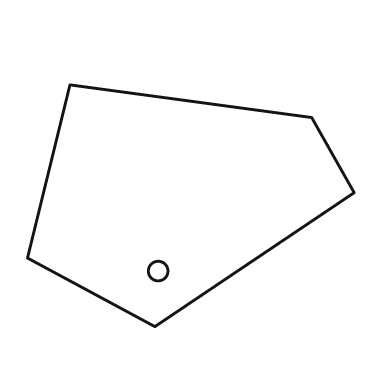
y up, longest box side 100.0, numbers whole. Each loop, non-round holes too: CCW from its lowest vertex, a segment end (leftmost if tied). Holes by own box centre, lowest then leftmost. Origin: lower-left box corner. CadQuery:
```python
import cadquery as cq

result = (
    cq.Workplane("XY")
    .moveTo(39.0, 0.0)
    .lineTo(100.0, 41.0)
    .lineTo(87.0, 64.0)
    .lineTo(13.0, 74.0)
    .lineTo(0.0, 21.0)
    .close()
    .moveTo(40.0, 17.0)
    .circle(3.0)
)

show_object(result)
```